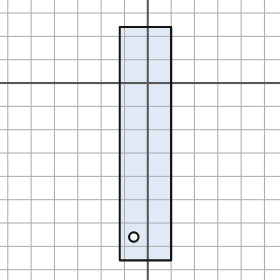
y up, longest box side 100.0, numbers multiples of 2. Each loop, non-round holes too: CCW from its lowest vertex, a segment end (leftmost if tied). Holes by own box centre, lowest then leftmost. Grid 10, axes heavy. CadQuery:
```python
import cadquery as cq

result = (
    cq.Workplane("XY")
    .moveTo(-12.0, -76.0)
    .lineTo(10.0, -76.0)
    .lineTo(10.0, 24.0)
    .lineTo(-12.0, 24.0)
    .close()
    .moveTo(-6.0, -66.0)
    .circle(2.0)
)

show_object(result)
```